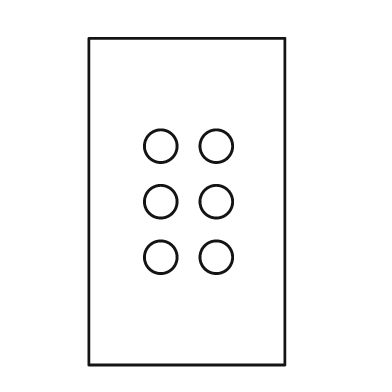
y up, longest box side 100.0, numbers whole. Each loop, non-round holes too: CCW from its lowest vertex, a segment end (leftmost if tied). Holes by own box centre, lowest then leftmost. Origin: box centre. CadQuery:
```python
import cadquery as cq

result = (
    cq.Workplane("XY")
    .moveTo(-30.0, -50.0)
    .lineTo(30.0, -50.0)
    .lineTo(30.0, 50.0)
    .lineTo(-30.0, 50.0)
    .close()
    .moveTo(-8.0, -17.0)
    .circle(5.0)
    .moveTo(9.0, -17.0)
    .circle(5.0)
    .moveTo(-8.0, 0.0)
    .circle(5.0)
    .moveTo(9.0, 0.0)
    .circle(5.0)
    .moveTo(-8.0, 17.0)
    .circle(5.0)
    .moveTo(9.0, 17.0)
    .circle(5.0)
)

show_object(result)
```